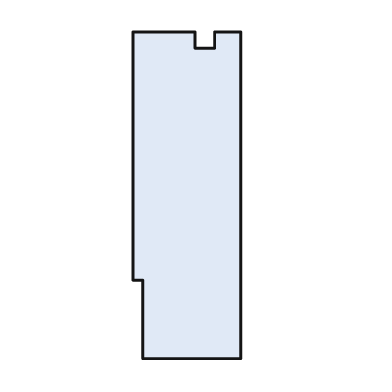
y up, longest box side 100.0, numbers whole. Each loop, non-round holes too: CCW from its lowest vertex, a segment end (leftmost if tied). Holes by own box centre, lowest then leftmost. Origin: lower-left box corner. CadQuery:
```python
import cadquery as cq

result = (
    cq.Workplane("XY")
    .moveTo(3.0, 0.0)
    .lineTo(33.0, 0.0)
    .lineTo(33.0, 100.0)
    .lineTo(25.0, 100.0)
    .lineTo(25.0, 95.0)
    .lineTo(19.0, 95.0)
    .lineTo(19.0, 100.0)
    .lineTo(0.0, 100.0)
    .lineTo(0.0, 24.0)
    .lineTo(3.0, 24.0)
    .close()
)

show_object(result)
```